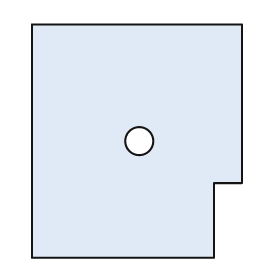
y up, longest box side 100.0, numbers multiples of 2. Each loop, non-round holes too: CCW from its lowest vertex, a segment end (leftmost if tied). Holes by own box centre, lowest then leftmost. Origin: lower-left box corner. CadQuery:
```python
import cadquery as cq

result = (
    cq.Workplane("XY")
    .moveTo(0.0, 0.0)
    .lineTo(78.0, 0.0)
    .lineTo(78.0, 32.0)
    .lineTo(90.0, 32.0)
    .lineTo(90.0, 100.0)
    .lineTo(0.0, 100.0)
    .close()
    .moveTo(46.0, 50.0)
    .circle(6.0)
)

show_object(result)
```